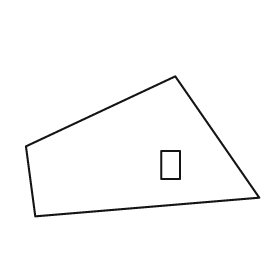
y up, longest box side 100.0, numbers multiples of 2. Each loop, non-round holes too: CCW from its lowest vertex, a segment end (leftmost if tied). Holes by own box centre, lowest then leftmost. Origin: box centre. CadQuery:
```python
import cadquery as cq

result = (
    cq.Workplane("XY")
    .moveTo(-46.0, -30.0)
    .lineTo(50.0, -22.0)
    .lineTo(14.0, 30.0)
    .lineTo(-50.0, 0.0)
    .close()
    .moveTo(8.0, -14.0)
    .lineTo(16.0, -14.0)
    .lineTo(16.0, -2.0)
    .lineTo(8.0, -2.0)
    .close()
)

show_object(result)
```